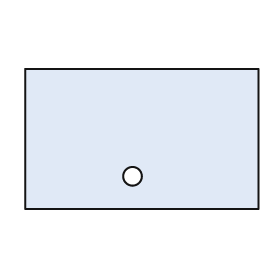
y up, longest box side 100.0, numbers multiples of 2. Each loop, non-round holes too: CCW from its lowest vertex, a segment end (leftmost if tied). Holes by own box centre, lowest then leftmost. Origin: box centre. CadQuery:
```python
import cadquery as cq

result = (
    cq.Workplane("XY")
    .moveTo(-50.0, -30.0)
    .lineTo(50.0, -30.0)
    .lineTo(50.0, 30.0)
    .lineTo(-50.0, 30.0)
    .close()
    .moveTo(-4.0, -16.0)
    .circle(4.0)
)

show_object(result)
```